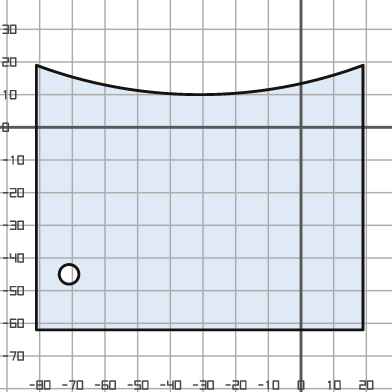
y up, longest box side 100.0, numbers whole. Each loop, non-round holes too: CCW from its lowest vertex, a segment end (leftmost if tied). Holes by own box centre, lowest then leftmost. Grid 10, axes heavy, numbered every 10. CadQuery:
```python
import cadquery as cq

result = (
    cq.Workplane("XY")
    .moveTo(-81.0, -62.0)
    .lineTo(19.0, -62.0)
    .lineTo(19.0, 19.0)
    .threePointArc((-31.0, 10.0), (-81.0, 19.0))
    .close()
    .moveTo(-71.0, -45.0)
    .circle(3.0)
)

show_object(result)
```